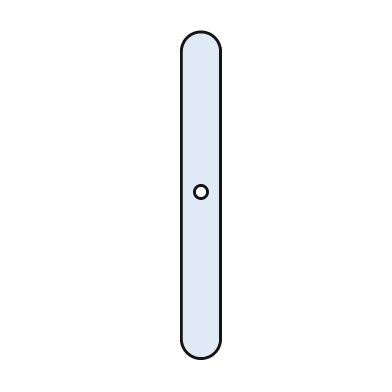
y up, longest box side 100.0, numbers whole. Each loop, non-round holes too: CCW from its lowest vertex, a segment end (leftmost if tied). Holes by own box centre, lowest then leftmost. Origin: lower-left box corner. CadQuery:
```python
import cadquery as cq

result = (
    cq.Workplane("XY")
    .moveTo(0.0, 6.0)
    .threePointArc((6.0, 0.0), (12.0, 6.0))
    .lineTo(12.0, 94.0)
    .threePointArc((6.0, 100.0), (0.0, 94.0))
    .close()
    .moveTo(6.0, 51.0)
    .circle(2.0)
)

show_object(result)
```